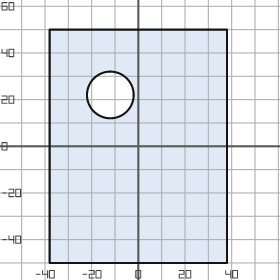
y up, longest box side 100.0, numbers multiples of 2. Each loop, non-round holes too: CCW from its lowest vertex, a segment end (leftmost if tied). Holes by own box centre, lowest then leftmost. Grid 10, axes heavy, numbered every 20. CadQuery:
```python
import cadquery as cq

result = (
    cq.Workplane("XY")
    .moveTo(-38.0, -50.0)
    .lineTo(38.0, -50.0)
    .lineTo(38.0, 50.0)
    .lineTo(-38.0, 50.0)
    .close()
    .moveTo(-12.0, 22.0)
    .circle(10.0)
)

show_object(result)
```